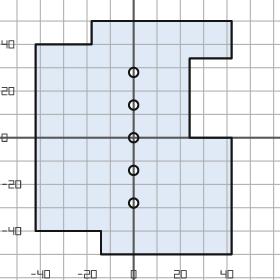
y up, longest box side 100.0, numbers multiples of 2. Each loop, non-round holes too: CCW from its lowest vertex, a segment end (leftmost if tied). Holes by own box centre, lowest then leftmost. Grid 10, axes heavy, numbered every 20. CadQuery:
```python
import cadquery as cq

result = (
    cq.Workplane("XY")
    .moveTo(-14.0, -50.0)
    .lineTo(42.0, -50.0)
    .lineTo(42.0, 0.0)
    .lineTo(24.0, 0.0)
    .lineTo(24.0, 34.0)
    .lineTo(42.0, 34.0)
    .lineTo(42.0, 50.0)
    .lineTo(-18.0, 50.0)
    .lineTo(-18.0, 40.0)
    .lineTo(-42.0, 40.0)
    .lineTo(-42.0, -40.0)
    .lineTo(-14.0, -40.0)
    .close()
    .moveTo(0.0, -28.0)
    .circle(2.0)
    .moveTo(0.0, -14.0)
    .circle(2.0)
    .moveTo(0.0, 0.0)
    .circle(2.0)
    .moveTo(0.0, 14.0)
    .circle(2.0)
    .moveTo(0.0, 28.0)
    .circle(2.0)
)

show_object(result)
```